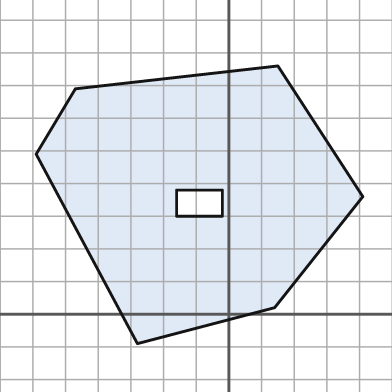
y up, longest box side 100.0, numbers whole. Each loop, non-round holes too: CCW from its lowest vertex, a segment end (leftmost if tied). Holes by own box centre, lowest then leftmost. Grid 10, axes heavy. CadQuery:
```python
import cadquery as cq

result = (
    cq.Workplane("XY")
    .moveTo(-28.0, -9.0)
    .lineTo(14.0, 2.0)
    .lineTo(41.0, 36.0)
    .lineTo(15.0, 76.0)
    .lineTo(-47.0, 69.0)
    .lineTo(-59.0, 49.0)
    .close()
    .moveTo(-16.0, 30.0)
    .lineTo(-2.0, 30.0)
    .lineTo(-2.0, 38.0)
    .lineTo(-16.0, 38.0)
    .close()
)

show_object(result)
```